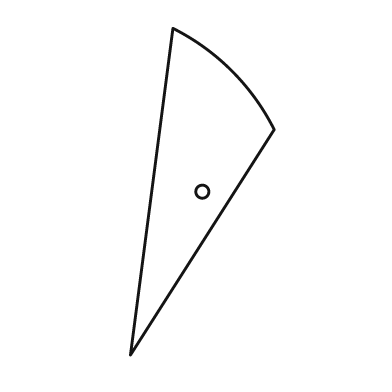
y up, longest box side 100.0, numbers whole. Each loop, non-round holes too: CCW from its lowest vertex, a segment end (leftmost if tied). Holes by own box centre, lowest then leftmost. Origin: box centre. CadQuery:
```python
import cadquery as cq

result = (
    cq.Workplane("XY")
    .moveTo(-22.0, -50.0)
    .lineTo(22.0, 19.0)
    .threePointArc((9.0, 37.0), (-9.0, 50.0))
    .close()
    .moveTo(0.0, 0.0)
    .circle(2.0)
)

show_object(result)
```